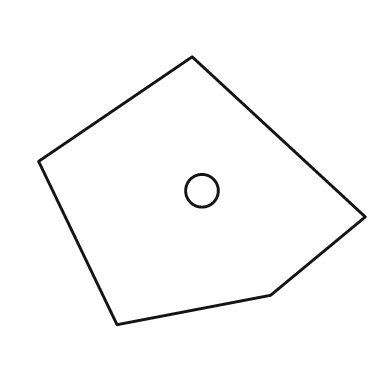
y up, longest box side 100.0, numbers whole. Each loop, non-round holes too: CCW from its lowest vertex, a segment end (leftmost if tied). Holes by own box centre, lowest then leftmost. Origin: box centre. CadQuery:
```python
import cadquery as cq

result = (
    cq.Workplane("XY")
    .moveTo(-26.0, -41.0)
    .lineTo(21.0, -32.0)
    .lineTo(50.0, -8.0)
    .lineTo(-3.0, 41.0)
    .lineTo(-50.0, 9.0)
    .close()
    .moveTo(0.0, 0.0)
    .circle(5.0)
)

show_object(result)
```